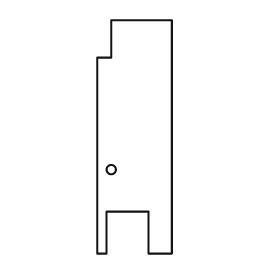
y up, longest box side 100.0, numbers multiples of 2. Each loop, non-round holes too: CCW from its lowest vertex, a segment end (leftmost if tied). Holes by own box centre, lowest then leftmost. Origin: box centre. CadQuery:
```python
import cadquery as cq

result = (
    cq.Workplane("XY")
    .moveTo(-16.0, -50.0)
    .lineTo(-12.0, -50.0)
    .lineTo(-12.0, -32.0)
    .lineTo(6.0, -32.0)
    .lineTo(6.0, -50.0)
    .lineTo(16.0, -50.0)
    .lineTo(16.0, 50.0)
    .lineTo(-10.0, 50.0)
    .lineTo(-10.0, 34.0)
    .lineTo(-16.0, 34.0)
    .close()
    .moveTo(-10.0, -14.0)
    .circle(2.0)
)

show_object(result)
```